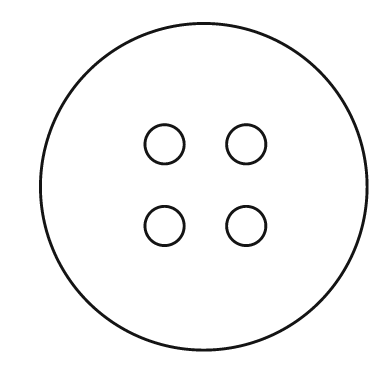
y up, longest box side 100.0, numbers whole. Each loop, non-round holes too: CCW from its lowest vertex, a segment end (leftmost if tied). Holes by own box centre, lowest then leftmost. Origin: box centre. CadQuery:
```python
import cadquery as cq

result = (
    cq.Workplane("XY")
    .moveTo(0.0, 0.0)
    .circle(50.0)
    .moveTo(-12.0, -12.0)
    .circle(6.0)
    .moveTo(13.0, -12.0)
    .circle(6.0)
    .moveTo(-12.0, 13.0)
    .circle(6.0)
    .moveTo(13.0, 13.0)
    .circle(6.0)
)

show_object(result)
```